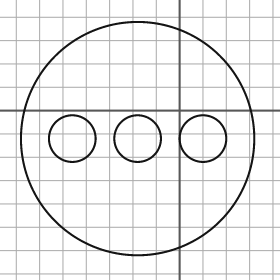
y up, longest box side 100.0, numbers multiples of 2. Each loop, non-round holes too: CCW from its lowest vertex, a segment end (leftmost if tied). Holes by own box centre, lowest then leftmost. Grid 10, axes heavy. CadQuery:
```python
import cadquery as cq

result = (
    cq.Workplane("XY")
    .moveTo(-18.0, -12.0)
    .circle(50.0)
    .moveTo(-46.0, -12.0)
    .circle(10.0)
    .moveTo(-18.0, -12.0)
    .circle(10.0)
    .moveTo(10.0, -12.0)
    .circle(10.0)
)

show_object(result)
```